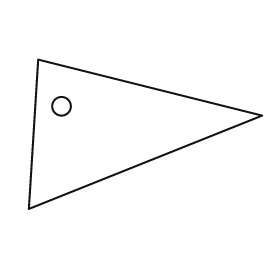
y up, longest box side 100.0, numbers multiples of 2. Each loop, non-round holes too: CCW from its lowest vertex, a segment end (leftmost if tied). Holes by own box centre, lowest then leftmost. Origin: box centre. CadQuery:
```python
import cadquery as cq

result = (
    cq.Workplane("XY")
    .moveTo(-50.0, -32.0)
    .lineTo(50.0, 8.0)
    .lineTo(-46.0, 32.0)
    .close()
    .moveTo(-36.0, 12.0)
    .circle(4.0)
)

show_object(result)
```